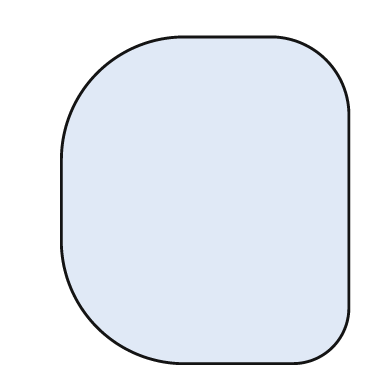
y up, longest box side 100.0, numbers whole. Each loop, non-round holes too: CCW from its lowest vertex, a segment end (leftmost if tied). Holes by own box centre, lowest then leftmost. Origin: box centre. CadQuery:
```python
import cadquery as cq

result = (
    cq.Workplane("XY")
    .moveTo(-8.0, -50.0)
    .lineTo(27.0, -50.0)
    .threePointArc((39.0, -45.0), (44.0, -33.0))
    .lineTo(44.0, 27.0)
    .threePointArc((37.0, 43.0), (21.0, 50.0))
    .lineTo(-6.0, 50.0)
    .threePointArc((-33.0, 39.0), (-44.0, 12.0))
    .lineTo(-44.0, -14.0)
    .threePointArc((-33.0, -39.0), (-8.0, -50.0))
    .close()
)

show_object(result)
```